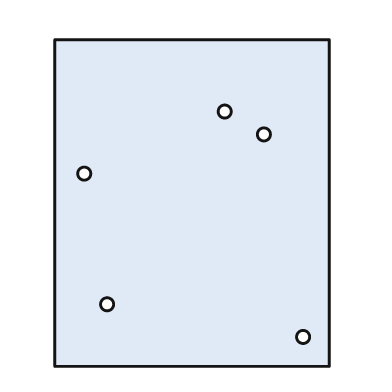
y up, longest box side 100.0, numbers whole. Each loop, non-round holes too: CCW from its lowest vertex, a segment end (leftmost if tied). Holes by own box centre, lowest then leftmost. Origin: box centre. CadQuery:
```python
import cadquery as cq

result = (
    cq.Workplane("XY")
    .moveTo(-42.0, -50.0)
    .lineTo(42.0, -50.0)
    .lineTo(42.0, 50.0)
    .lineTo(-42.0, 50.0)
    .close()
    .moveTo(34.0, -41.0)
    .circle(2.0)
    .moveTo(-26.0, -31.0)
    .circle(2.0)
    .moveTo(-33.0, 9.0)
    .circle(2.0)
    .moveTo(22.0, 21.0)
    .circle(2.0)
    .moveTo(10.0, 28.0)
    .circle(2.0)
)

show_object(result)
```